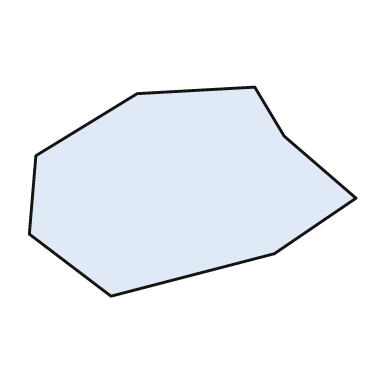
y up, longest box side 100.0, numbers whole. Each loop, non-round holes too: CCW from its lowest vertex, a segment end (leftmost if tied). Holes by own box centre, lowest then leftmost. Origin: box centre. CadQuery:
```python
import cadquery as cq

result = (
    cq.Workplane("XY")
    .moveTo(-25.0, -32.0)
    .lineTo(25.0, -19.0)
    .lineTo(50.0, -2.0)
    .lineTo(28.0, 17.0)
    .lineTo(19.0, 32.0)
    .lineTo(-17.0, 30.0)
    .lineTo(-48.0, 11.0)
    .lineTo(-50.0, -13.0)
    .close()
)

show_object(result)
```